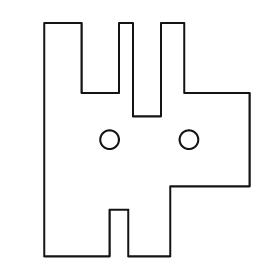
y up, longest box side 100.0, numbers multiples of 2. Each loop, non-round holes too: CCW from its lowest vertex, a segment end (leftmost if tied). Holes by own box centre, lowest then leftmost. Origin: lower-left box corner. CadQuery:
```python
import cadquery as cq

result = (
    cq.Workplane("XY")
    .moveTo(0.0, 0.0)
    .lineTo(28.0, 0.0)
    .lineTo(28.0, 20.0)
    .lineTo(36.0, 20.0)
    .lineTo(36.0, 0.0)
    .lineTo(54.0, 0.0)
    .lineTo(54.0, 30.0)
    .lineTo(88.0, 30.0)
    .lineTo(88.0, 70.0)
    .lineTo(60.0, 70.0)
    .lineTo(60.0, 100.0)
    .lineTo(50.0, 100.0)
    .lineTo(50.0, 60.0)
    .lineTo(38.0, 60.0)
    .lineTo(38.0, 100.0)
    .lineTo(32.0, 100.0)
    .lineTo(32.0, 70.0)
    .lineTo(16.0, 70.0)
    .lineTo(16.0, 100.0)
    .lineTo(0.0, 100.0)
    .close()
    .moveTo(28.0, 50.0)
    .circle(4.0)
    .moveTo(62.0, 50.0)
    .circle(4.0)
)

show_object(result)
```